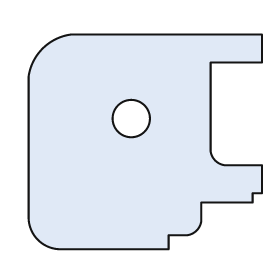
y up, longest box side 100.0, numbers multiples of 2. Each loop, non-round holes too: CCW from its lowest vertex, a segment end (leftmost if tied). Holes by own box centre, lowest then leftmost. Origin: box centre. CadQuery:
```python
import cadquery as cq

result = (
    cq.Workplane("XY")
    .moveTo(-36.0, -46.0)
    .lineTo(10.0, -46.0)
    .lineTo(10.0, -40.0)
    .lineTo(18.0, -40.0)
    .threePointArc((22.0, -38.0), (24.0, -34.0))
    .lineTo(24.0, -26.0)
    .lineTo(46.0, -26.0)
    .lineTo(46.0, -22.0)
    .lineTo(50.0, -22.0)
    .lineTo(50.0, -10.0)
    .lineTo(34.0, -10.0)
    .threePointArc((30.0, -8.0), (28.0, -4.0))
    .lineTo(28.0, 34.0)
    .lineTo(50.0, 34.0)
    .lineTo(50.0, 46.0)
    .lineTo(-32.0, 46.0)
    .threePointArc((-44.0, 40.0), (-50.0, 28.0))
    .lineTo(-50.0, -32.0)
    .threePointArc((-46.0, -42.0), (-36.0, -46.0))
    .close()
    .moveTo(-6.0, 10.0)
    .circle(8.0)
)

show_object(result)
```